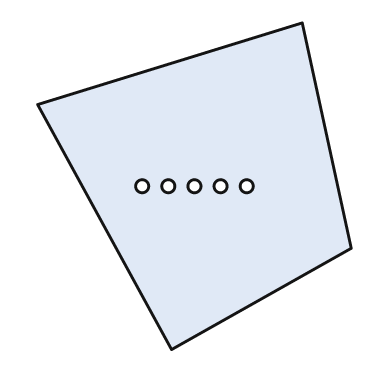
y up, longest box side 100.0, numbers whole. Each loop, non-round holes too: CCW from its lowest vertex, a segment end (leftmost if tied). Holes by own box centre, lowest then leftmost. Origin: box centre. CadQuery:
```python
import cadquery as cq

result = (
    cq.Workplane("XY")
    .moveTo(-7.0, -50.0)
    .lineTo(48.0, -19.0)
    .lineTo(33.0, 50.0)
    .lineTo(-48.0, 25.0)
    .close()
    .moveTo(-16.0, 0.0)
    .circle(2.0)
    .moveTo(-8.0, 0.0)
    .circle(2.0)
    .moveTo(0.0, 0.0)
    .circle(2.0)
    .moveTo(8.0, 0.0)
    .circle(2.0)
    .moveTo(16.0, 0.0)
    .circle(2.0)
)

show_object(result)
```